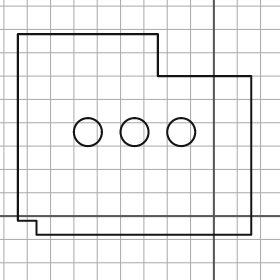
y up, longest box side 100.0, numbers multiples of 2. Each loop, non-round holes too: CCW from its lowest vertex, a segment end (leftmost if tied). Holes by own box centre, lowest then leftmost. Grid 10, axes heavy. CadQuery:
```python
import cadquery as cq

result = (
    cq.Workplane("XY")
    .moveTo(-76.0, -8.0)
    .lineTo(16.0, -8.0)
    .lineTo(16.0, 60.0)
    .lineTo(-24.0, 60.0)
    .lineTo(-24.0, 78.0)
    .lineTo(-84.0, 78.0)
    .lineTo(-84.0, -2.0)
    .lineTo(-76.0, -2.0)
    .close()
    .moveTo(-54.0, 36.0)
    .circle(6.0)
    .moveTo(-34.0, 36.0)
    .circle(6.0)
    .moveTo(-14.0, 36.0)
    .circle(6.0)
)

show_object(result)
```